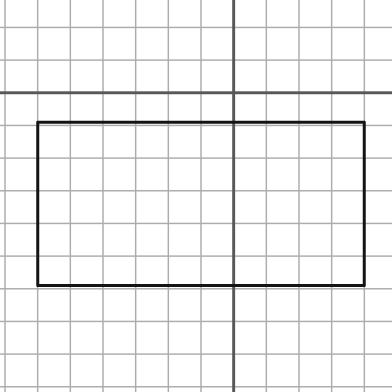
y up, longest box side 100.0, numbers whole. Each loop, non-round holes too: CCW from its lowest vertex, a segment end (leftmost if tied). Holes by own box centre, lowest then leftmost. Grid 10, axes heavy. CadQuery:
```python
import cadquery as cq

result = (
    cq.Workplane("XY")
    .moveTo(-60.0, -59.0)
    .lineTo(40.0, -59.0)
    .lineTo(40.0, -9.0)
    .lineTo(-60.0, -9.0)
    .close()
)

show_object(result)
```